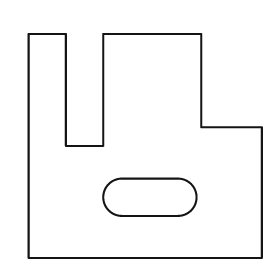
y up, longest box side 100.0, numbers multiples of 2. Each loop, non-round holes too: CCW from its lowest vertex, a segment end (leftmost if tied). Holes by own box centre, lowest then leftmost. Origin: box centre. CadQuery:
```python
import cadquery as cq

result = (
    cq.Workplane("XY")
    .moveTo(-50.0, -48.0)
    .lineTo(50.0, -48.0)
    .lineTo(50.0, 8.0)
    .lineTo(24.0, 8.0)
    .lineTo(24.0, 48.0)
    .lineTo(-18.0, 48.0)
    .lineTo(-18.0, 0.0)
    .lineTo(-34.0, 0.0)
    .lineTo(-34.0, 48.0)
    .lineTo(-50.0, 48.0)
    .close()
    .moveTo(-10.0, -30.0)
    .lineTo(14.0, -30.0)
    .threePointArc((22.0, -22.0), (14.0, -14.0))
    .lineTo(-10.0, -14.0)
    .threePointArc((-18.0, -22.0), (-10.0, -30.0))
    .close()
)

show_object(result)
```